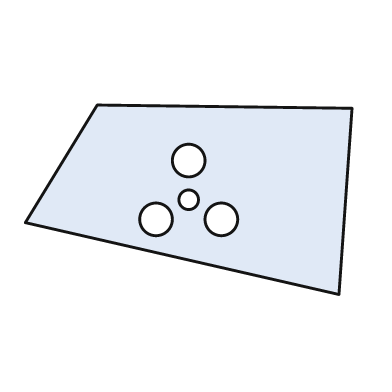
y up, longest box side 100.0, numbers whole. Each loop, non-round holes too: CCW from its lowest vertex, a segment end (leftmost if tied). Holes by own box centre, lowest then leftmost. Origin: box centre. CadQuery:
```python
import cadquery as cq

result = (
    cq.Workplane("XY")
    .moveTo(46.0, -29.0)
    .lineTo(50.0, 28.0)
    .lineTo(-28.0, 29.0)
    .lineTo(-50.0, -7.0)
    .close()
    .moveTo(-10.0, -6.0)
    .circle(5.0)
    .moveTo(10.0, -6.0)
    .circle(5.0)
    .moveTo(0.0, 0.0)
    .circle(3.0)
    .moveTo(0.0, 12.0)
    .circle(5.0)
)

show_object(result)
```